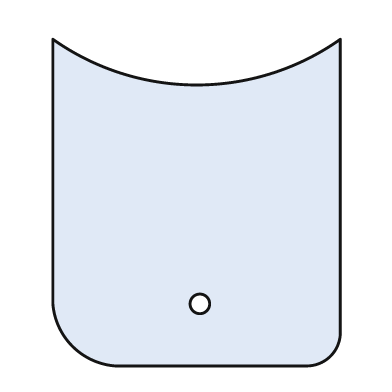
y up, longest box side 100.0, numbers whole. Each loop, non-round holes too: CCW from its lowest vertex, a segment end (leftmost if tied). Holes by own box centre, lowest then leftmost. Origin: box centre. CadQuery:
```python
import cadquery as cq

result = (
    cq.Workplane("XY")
    .moveTo(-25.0, -50.0)
    .lineTo(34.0, -50.0)
    .threePointArc((41.0, -47.0), (44.0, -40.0))
    .lineTo(44.0, 50.0)
    .threePointArc((0.0, 36.0), (-44.0, 50.0))
    .lineTo(-44.0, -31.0)
    .threePointArc((-38.0, -44.0), (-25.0, -50.0))
    .close()
    .moveTo(1.0, -31.0)
    .circle(3.0)
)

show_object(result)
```